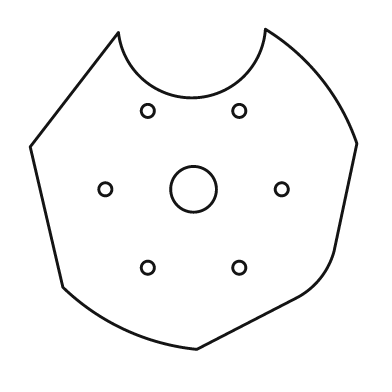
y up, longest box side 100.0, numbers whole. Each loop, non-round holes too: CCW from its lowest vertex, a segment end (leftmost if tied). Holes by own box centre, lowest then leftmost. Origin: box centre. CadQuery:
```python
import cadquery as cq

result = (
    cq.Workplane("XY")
    .moveTo(1.0, -49.0)
    .lineTo(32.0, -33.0)
    .threePointArc((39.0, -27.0), (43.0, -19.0))
    .lineTo(50.0, 14.0)
    .threePointArc((39.0, 34.0), (22.0, 49.0))
    .threePointArc((0.0, 28.0), (-23.0, 48.0))
    .lineTo(-50.0, 13.0)
    .lineTo(-40.0, -30.0)
    .threePointArc((-21.0, -43.0), (1.0, -49.0))
    .close()
    .moveTo(-14.0, -24.0)
    .circle(2.0)
    .moveTo(14.0, -24.0)
    .circle(2.0)
    .moveTo(-27.0, 0.0)
    .circle(2.0)
    .moveTo(0.0, 0.0)
    .circle(7.0)
    .moveTo(27.0, 0.0)
    .circle(2.0)
    .moveTo(-14.0, 24.0)
    .circle(2.0)
    .moveTo(14.0, 24.0)
    .circle(2.0)
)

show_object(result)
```